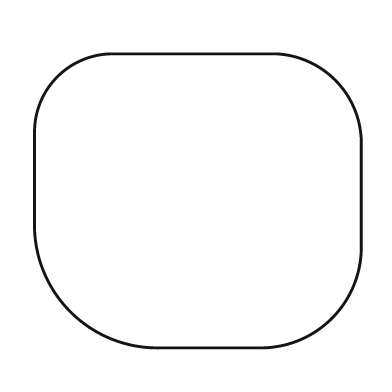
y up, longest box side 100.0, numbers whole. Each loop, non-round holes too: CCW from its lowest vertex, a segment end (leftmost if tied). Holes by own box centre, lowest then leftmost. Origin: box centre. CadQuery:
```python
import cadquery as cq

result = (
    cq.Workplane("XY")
    .moveTo(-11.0, -45.0)
    .lineTo(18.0, -45.0)
    .threePointArc((41.0, -36.0), (50.0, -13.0))
    .lineTo(50.0, 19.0)
    .threePointArc((42.0, 37.0), (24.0, 45.0))
    .lineTo(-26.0, 45.0)
    .threePointArc((-43.0, 38.0), (-50.0, 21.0))
    .lineTo(-50.0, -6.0)
    .threePointArc((-39.0, -34.0), (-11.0, -45.0))
    .close()
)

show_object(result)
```